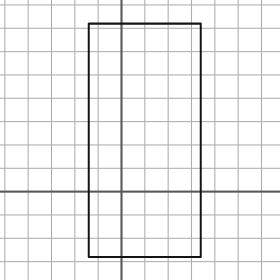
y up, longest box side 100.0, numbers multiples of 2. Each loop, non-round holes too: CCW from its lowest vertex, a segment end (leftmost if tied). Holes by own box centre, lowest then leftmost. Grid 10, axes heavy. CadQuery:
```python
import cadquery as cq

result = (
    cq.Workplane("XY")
    .moveTo(-14.0, -28.0)
    .lineTo(34.0, -28.0)
    .lineTo(34.0, 72.0)
    .lineTo(-14.0, 72.0)
    .close()
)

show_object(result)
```